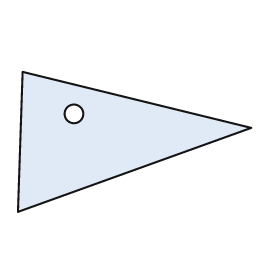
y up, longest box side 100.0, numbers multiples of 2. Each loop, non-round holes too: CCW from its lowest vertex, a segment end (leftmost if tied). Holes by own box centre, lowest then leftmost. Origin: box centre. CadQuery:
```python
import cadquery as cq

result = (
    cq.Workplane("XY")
    .moveTo(-50.0, -30.0)
    .lineTo(50.0, 6.0)
    .lineTo(-48.0, 30.0)
    .close()
    .moveTo(-26.0, 12.0)
    .circle(4.0)
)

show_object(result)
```